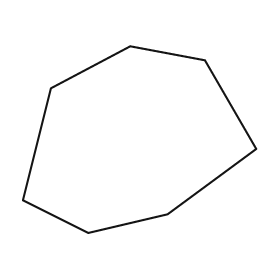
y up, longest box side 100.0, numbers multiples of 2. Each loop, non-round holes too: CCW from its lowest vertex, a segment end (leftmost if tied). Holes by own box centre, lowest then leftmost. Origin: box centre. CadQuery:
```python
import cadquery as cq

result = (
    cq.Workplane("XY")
    .moveTo(-22.0, -40.0)
    .lineTo(12.0, -32.0)
    .lineTo(50.0, -4.0)
    .lineTo(28.0, 34.0)
    .lineTo(-4.0, 40.0)
    .lineTo(-38.0, 22.0)
    .lineTo(-50.0, -26.0)
    .close()
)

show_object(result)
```